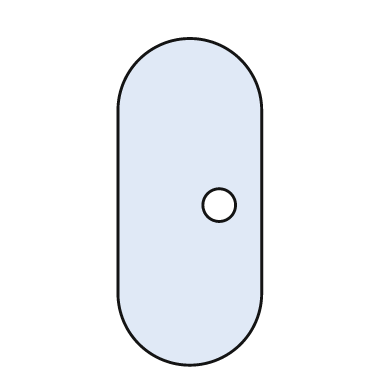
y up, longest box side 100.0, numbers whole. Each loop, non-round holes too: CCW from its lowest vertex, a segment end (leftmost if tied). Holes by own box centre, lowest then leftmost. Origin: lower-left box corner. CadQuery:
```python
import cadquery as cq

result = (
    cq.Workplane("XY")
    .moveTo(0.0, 22.0)
    .threePointArc((22.0, 0.0), (44.0, 22.0))
    .lineTo(44.0, 78.0)
    .threePointArc((22.0, 100.0), (0.0, 78.0))
    .close()
    .moveTo(31.0, 49.0)
    .circle(5.0)
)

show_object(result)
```